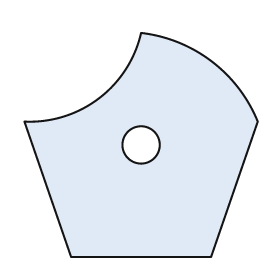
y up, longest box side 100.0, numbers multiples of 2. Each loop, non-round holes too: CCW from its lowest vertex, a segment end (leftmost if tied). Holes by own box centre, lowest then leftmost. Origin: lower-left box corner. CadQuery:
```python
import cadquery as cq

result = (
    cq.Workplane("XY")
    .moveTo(20.0, 0.0)
    .lineTo(80.0, 0.0)
    .lineTo(100.0, 58.0)
    .threePointArc((80.0, 84.0), (50.0, 96.0))
    .threePointArc((32.0, 68.0), (0.0, 58.0))
    .close()
    .moveTo(50.0, 48.0)
    .circle(8.0)
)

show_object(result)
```